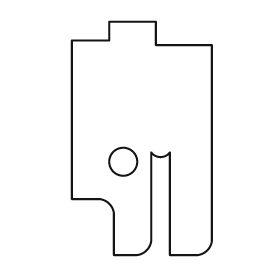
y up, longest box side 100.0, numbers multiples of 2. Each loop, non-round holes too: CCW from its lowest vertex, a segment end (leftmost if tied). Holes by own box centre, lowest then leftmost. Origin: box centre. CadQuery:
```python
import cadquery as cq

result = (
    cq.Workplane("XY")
    .moveTo(-12.0, -50.0)
    .lineTo(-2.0, -50.0)
    .threePointArc((2.0, -48.0), (4.0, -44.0))
    .lineTo(4.0, -6.0)
    .threePointArc((8.0, -8.0), (12.0, -6.0))
    .lineTo(12.0, -50.0)
    .lineTo(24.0, -50.0)
    .threePointArc((28.0, -48.0), (30.0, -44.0))
    .lineTo(30.0, 40.0)
    .lineTo(6.0, 40.0)
    .lineTo(6.0, 50.0)
    .lineTo(-14.0, 50.0)
    .lineTo(-14.0, 42.0)
    .lineTo(-30.0, 42.0)
    .lineTo(-30.0, -26.0)
    .lineTo(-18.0, -26.0)
    .threePointArc((-14.0, -28.0), (-12.0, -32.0))
    .close()
    .moveTo(-8.0, -10.0)
    .circle(6.0)
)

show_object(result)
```